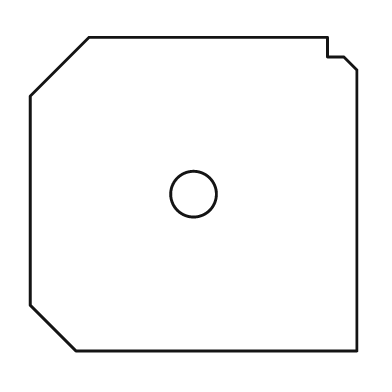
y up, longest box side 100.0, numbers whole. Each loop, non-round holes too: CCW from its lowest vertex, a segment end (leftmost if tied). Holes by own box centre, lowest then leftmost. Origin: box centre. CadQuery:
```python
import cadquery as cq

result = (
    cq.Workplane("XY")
    .moveTo(-36.0, -48.0)
    .lineTo(50.0, -48.0)
    .lineTo(50.0, 38.0)
    .lineTo(46.0, 42.0)
    .lineTo(41.0, 42.0)
    .lineTo(41.0, 48.0)
    .lineTo(-32.0, 48.0)
    .lineTo(-50.0, 30.0)
    .lineTo(-50.0, -34.0)
    .close()
    .moveTo(0.0, 0.0)
    .circle(7.0)
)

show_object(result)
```